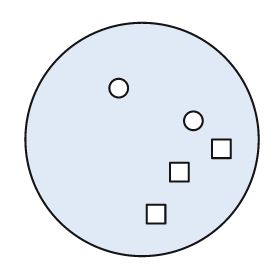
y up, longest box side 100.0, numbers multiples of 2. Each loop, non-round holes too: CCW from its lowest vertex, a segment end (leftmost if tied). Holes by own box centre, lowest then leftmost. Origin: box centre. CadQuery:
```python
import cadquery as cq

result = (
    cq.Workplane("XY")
    .moveTo(0.0, 0.0)
    .circle(50.0)
    .moveTo(2.0, -36.0)
    .lineTo(10.0, -36.0)
    .lineTo(10.0, -28.0)
    .lineTo(2.0, -28.0)
    .close()
    .moveTo(12.0, -18.0)
    .lineTo(20.0, -18.0)
    .lineTo(20.0, -10.0)
    .lineTo(12.0, -10.0)
    .close()
    .moveTo(30.0, -8.0)
    .lineTo(38.0, -8.0)
    .lineTo(38.0, 0.0)
    .lineTo(30.0, 0.0)
    .close()
    .moveTo(22.0, 8.0)
    .circle(4.0)
    .moveTo(-10.0, 22.0)
    .circle(4.0)
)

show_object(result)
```